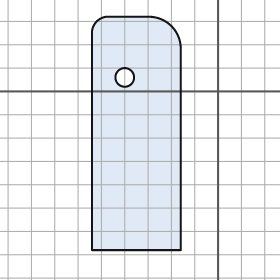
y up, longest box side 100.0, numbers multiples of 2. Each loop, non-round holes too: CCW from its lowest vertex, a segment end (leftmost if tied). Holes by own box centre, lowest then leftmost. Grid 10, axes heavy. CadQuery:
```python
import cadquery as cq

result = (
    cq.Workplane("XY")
    .moveTo(-54.0, -68.0)
    .lineTo(-16.0, -68.0)
    .lineTo(-16.0, 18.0)
    .threePointArc((-20.0, 28.0), (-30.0, 32.0))
    .lineTo(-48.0, 32.0)
    .threePointArc((-52.0, 30.0), (-54.0, 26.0))
    .close()
    .moveTo(-40.0, 6.0)
    .circle(4.0)
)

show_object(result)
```